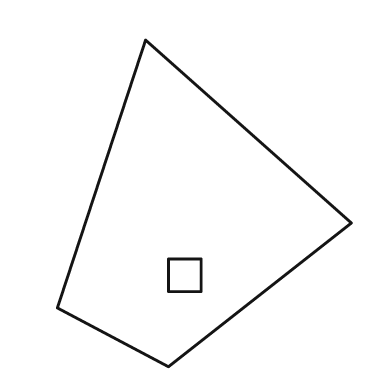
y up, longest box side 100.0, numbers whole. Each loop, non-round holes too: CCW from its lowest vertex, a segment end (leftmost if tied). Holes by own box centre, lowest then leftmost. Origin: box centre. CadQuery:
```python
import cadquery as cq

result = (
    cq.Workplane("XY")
    .moveTo(-11.0, -50.0)
    .lineTo(45.0, -6.0)
    .lineTo(-18.0, 50.0)
    .lineTo(-45.0, -32.0)
    .close()
    .moveTo(-11.0, -27.0)
    .lineTo(-1.0, -27.0)
    .lineTo(-1.0, -17.0)
    .lineTo(-11.0, -17.0)
    .close()
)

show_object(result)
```